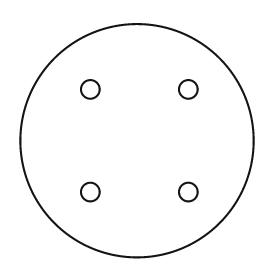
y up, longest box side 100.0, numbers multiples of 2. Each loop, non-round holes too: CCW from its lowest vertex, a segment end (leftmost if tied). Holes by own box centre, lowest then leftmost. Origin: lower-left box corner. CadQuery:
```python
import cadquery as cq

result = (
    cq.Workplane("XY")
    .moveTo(50.0, 50.0)
    .circle(50.0)
    .moveTo(30.0, 28.0)
    .circle(4.0)
    .moveTo(72.0, 28.0)
    .circle(4.0)
    .moveTo(30.0, 72.0)
    .circle(4.0)
    .moveTo(72.0, 72.0)
    .circle(4.0)
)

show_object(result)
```